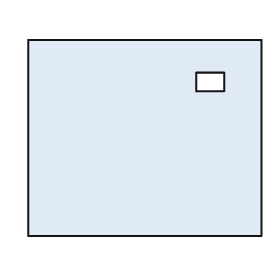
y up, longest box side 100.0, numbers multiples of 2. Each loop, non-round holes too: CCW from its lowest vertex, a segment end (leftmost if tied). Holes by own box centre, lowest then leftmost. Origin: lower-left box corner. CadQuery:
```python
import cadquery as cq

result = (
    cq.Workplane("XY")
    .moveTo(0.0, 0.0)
    .lineTo(100.0, 0.0)
    .lineTo(100.0, 84.0)
    .lineTo(0.0, 84.0)
    .close()
    .moveTo(72.0, 62.0)
    .lineTo(84.0, 62.0)
    .lineTo(84.0, 70.0)
    .lineTo(72.0, 70.0)
    .close()
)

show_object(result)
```